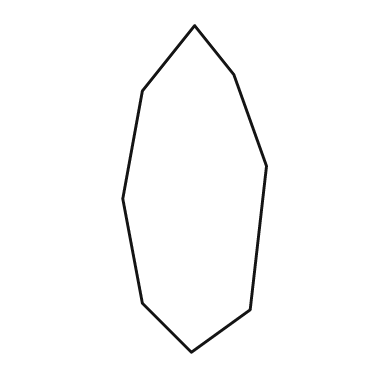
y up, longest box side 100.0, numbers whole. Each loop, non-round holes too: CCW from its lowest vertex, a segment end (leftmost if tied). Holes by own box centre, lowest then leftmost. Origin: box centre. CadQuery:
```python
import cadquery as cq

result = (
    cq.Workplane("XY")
    .moveTo(-1.0, -50.0)
    .lineTo(17.0, -37.0)
    .lineTo(22.0, 7.0)
    .lineTo(12.0, 35.0)
    .lineTo(0.0, 50.0)
    .lineTo(-16.0, 30.0)
    .lineTo(-22.0, -3.0)
    .lineTo(-16.0, -35.0)
    .close()
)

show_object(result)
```